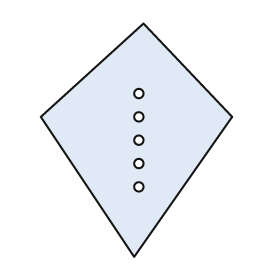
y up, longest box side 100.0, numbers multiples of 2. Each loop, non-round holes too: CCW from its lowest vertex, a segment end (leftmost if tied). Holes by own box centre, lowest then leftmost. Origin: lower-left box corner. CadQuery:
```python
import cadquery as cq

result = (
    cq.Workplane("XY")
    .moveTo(40.0, 0.0)
    .lineTo(82.0, 60.0)
    .lineTo(44.0, 100.0)
    .lineTo(0.0, 60.0)
    .close()
    .moveTo(42.0, 30.0)
    .circle(2.0)
    .moveTo(42.0, 40.0)
    .circle(2.0)
    .moveTo(42.0, 50.0)
    .circle(2.0)
    .moveTo(42.0, 60.0)
    .circle(2.0)
    .moveTo(42.0, 70.0)
    .circle(2.0)
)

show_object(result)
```